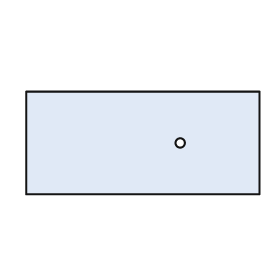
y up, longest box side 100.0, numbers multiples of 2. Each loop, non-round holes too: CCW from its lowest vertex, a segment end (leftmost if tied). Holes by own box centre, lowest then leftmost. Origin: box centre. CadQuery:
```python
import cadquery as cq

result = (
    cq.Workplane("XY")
    .moveTo(-50.0, -22.0)
    .lineTo(50.0, -22.0)
    .lineTo(50.0, 22.0)
    .lineTo(-50.0, 22.0)
    .close()
    .moveTo(16.0, 0.0)
    .circle(2.0)
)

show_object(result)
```